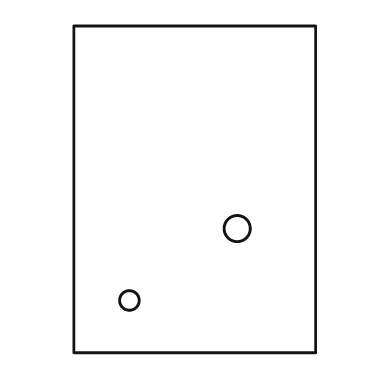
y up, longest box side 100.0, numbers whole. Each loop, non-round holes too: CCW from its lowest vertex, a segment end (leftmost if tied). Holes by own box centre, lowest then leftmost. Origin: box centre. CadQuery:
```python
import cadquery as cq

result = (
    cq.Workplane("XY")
    .moveTo(-37.0, -50.0)
    .lineTo(37.0, -50.0)
    .lineTo(37.0, 50.0)
    .lineTo(-37.0, 50.0)
    .close()
    .moveTo(-20.0, -34.0)
    .circle(3.0)
    .moveTo(13.0, -12.0)
    .circle(4.0)
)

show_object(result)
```